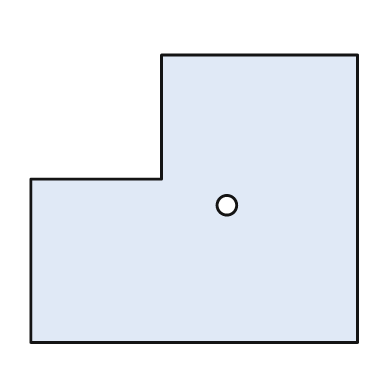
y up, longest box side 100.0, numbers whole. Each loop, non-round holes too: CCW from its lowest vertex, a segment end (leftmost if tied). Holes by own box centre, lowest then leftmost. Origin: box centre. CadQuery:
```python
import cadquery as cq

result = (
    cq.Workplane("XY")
    .moveTo(-50.0, -44.0)
    .lineTo(50.0, -44.0)
    .lineTo(50.0, 44.0)
    .lineTo(-10.0, 44.0)
    .lineTo(-10.0, 6.0)
    .lineTo(-50.0, 6.0)
    .close()
    .moveTo(10.0, -2.0)
    .circle(3.0)
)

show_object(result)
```